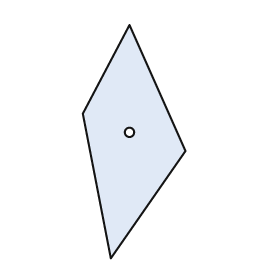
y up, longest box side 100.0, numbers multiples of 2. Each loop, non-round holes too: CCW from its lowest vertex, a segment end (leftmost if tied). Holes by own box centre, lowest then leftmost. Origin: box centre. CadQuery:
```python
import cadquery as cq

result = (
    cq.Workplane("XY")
    .moveTo(-10.0, -50.0)
    .lineTo(22.0, -4.0)
    .lineTo(-2.0, 50.0)
    .lineTo(-22.0, 12.0)
    .close()
    .moveTo(-2.0, 4.0)
    .circle(2.0)
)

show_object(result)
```